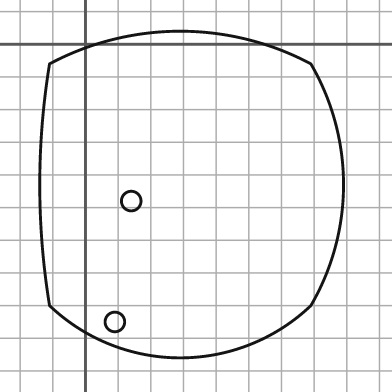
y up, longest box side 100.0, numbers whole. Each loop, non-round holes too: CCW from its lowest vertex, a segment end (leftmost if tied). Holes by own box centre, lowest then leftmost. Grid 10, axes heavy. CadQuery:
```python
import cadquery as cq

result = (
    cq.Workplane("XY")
    .moveTo(-11.0, -80.0)
    .threePointArc((29.0, -96.0), (69.0, -80.0))
    .threePointArc((79.0, -43.0), (69.0, -6.0))
    .threePointArc((29.0, 4.0), (-11.0, -6.0))
    .threePointArc((-14.0, -43.0), (-11.0, -80.0))
    .close()
    .moveTo(9.0, -85.0)
    .circle(3.0)
    .moveTo(14.0, -48.0)
    .circle(3.0)
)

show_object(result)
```